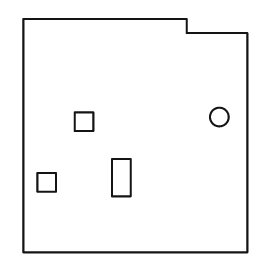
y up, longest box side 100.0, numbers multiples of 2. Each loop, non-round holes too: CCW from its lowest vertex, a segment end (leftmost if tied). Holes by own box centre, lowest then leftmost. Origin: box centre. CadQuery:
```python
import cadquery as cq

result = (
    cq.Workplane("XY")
    .moveTo(-48.0, -50.0)
    .lineTo(48.0, -50.0)
    .lineTo(48.0, 44.0)
    .lineTo(22.0, 44.0)
    .lineTo(22.0, 50.0)
    .lineTo(-48.0, 50.0)
    .close()
    .moveTo(-42.0, -24.0)
    .lineTo(-34.0, -24.0)
    .lineTo(-34.0, -16.0)
    .lineTo(-42.0, -16.0)
    .close()
    .moveTo(-10.0, -26.0)
    .lineTo(-2.0, -26.0)
    .lineTo(-2.0, -10.0)
    .lineTo(-10.0, -10.0)
    .close()
    .moveTo(-26.0, 2.0)
    .lineTo(-18.0, 2.0)
    .lineTo(-18.0, 10.0)
    .lineTo(-26.0, 10.0)
    .close()
    .moveTo(36.0, 8.0)
    .circle(4.0)
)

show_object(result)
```